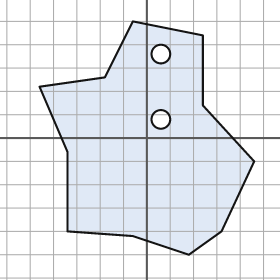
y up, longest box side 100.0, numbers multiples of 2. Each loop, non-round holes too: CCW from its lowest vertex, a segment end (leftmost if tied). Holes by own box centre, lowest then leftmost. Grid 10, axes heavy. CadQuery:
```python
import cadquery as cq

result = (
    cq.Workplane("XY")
    .moveTo(18.0, -50.0)
    .lineTo(32.0, -40.0)
    .lineTo(46.0, -10.0)
    .lineTo(24.0, 14.0)
    .lineTo(24.0, 44.0)
    .lineTo(-6.0, 50.0)
    .lineTo(-18.0, 26.0)
    .lineTo(-46.0, 22.0)
    .lineTo(-34.0, -6.0)
    .lineTo(-34.0, -40.0)
    .lineTo(-6.0, -42.0)
    .close()
    .moveTo(6.0, 8.0)
    .circle(4.0)
    .moveTo(6.0, 36.0)
    .circle(4.0)
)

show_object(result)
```